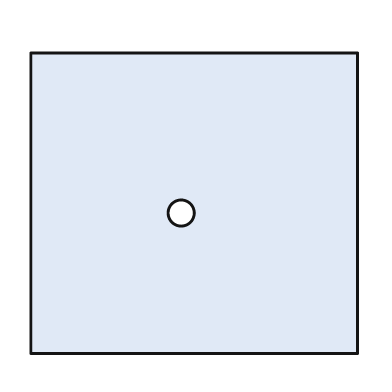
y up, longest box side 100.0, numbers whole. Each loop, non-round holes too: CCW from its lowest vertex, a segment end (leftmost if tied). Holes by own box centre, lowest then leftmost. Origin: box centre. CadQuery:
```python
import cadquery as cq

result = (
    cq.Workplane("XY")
    .moveTo(-50.0, -46.0)
    .lineTo(50.0, -46.0)
    .lineTo(50.0, 46.0)
    .lineTo(-50.0, 46.0)
    .close()
    .moveTo(-4.0, -3.0)
    .circle(4.0)
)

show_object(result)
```